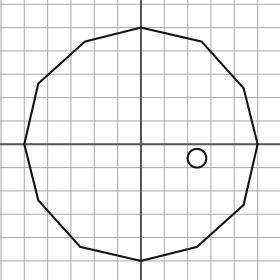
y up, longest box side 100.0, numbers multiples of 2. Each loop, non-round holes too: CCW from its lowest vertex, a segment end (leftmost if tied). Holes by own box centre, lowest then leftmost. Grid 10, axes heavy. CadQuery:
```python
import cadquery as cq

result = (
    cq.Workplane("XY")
    .moveTo(0.0, -50.0)
    .lineTo(24.0, -44.0)
    .lineTo(44.0, -26.0)
    .lineTo(50.0, 0.0)
    .lineTo(44.0, 24.0)
    .lineTo(26.0, 44.0)
    .lineTo(0.0, 50.0)
    .lineTo(-24.0, 44.0)
    .lineTo(-44.0, 26.0)
    .lineTo(-50.0, 0.0)
    .lineTo(-44.0, -24.0)
    .lineTo(-26.0, -44.0)
    .close()
    .moveTo(24.0, -6.0)
    .circle(4.0)
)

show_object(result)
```